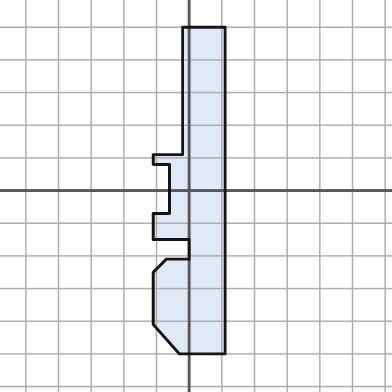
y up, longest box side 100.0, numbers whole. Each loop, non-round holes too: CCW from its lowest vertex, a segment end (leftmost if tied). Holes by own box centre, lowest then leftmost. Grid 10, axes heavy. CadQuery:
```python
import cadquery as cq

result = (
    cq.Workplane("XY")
    .moveTo(-3.0, -50.0)
    .lineTo(11.0, -50.0)
    .lineTo(11.0, 50.0)
    .lineTo(-2.0, 50.0)
    .lineTo(-2.0, 11.0)
    .lineTo(-11.0, 11.0)
    .lineTo(-11.0, 8.0)
    .lineTo(-6.0, 8.0)
    .lineTo(-6.0, -7.0)
    .lineTo(-11.0, -7.0)
    .lineTo(-11.0, -15.0)
    .lineTo(0.0, -15.0)
    .lineTo(0.0, -21.0)
    .lineTo(-7.0, -21.0)
    .lineTo(-11.0, -25.0)
    .lineTo(-11.0, -41.0)
    .close()
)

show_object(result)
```